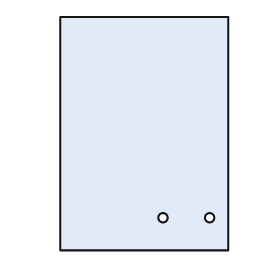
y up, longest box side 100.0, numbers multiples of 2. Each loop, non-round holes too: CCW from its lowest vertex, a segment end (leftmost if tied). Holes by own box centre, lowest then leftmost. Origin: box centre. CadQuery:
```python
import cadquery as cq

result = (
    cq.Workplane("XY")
    .moveTo(-36.0, -50.0)
    .lineTo(36.0, -50.0)
    .lineTo(36.0, 50.0)
    .lineTo(-36.0, 50.0)
    .close()
    .moveTo(8.0, -36.0)
    .circle(2.0)
    .moveTo(28.0, -36.0)
    .circle(2.0)
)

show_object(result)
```